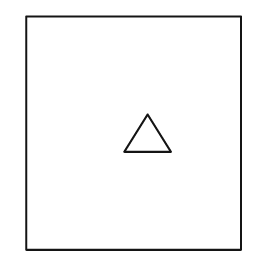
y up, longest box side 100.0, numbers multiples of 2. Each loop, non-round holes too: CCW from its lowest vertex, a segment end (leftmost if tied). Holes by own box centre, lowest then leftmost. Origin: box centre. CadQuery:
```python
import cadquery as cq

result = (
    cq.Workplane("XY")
    .moveTo(-46.0, -50.0)
    .lineTo(46.0, -50.0)
    .lineTo(46.0, 50.0)
    .lineTo(-46.0, 50.0)
    .close()
    .moveTo(-4.0, -8.0)
    .lineTo(16.0, -8.0)
    .lineTo(6.0, 8.0)
    .close()
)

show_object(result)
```